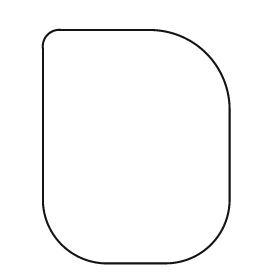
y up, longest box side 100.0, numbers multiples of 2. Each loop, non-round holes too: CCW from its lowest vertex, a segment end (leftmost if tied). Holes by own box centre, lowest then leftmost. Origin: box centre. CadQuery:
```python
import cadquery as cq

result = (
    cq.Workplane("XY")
    .moveTo(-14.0, -50.0)
    .lineTo(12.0, -50.0)
    .threePointArc((32.0, -42.0), (40.0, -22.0))
    .lineTo(40.0, 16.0)
    .threePointArc((30.0, 40.0), (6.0, 50.0))
    .lineTo(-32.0, 50.0)
    .threePointArc((-38.0, 48.0), (-40.0, 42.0))
    .lineTo(-40.0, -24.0)
    .threePointArc((-32.0, -42.0), (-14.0, -50.0))
    .close()
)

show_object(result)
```